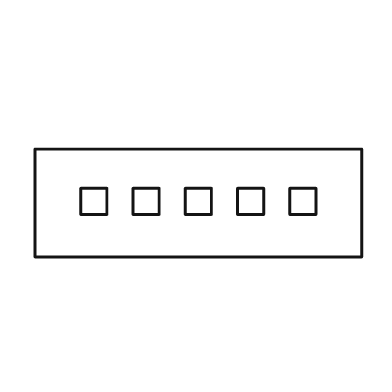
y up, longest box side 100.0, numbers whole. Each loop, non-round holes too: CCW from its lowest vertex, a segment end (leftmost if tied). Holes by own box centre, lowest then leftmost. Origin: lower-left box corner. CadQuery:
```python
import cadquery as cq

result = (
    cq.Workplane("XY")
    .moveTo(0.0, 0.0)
    .lineTo(100.0, 0.0)
    .lineTo(100.0, 33.0)
    .lineTo(0.0, 33.0)
    .close()
    .moveTo(14.0, 13.0)
    .lineTo(22.0, 13.0)
    .lineTo(22.0, 21.0)
    .lineTo(14.0, 21.0)
    .close()
    .moveTo(30.0, 13.0)
    .lineTo(38.0, 13.0)
    .lineTo(38.0, 21.0)
    .lineTo(30.0, 21.0)
    .close()
    .moveTo(46.0, 13.0)
    .lineTo(54.0, 13.0)
    .lineTo(54.0, 21.0)
    .lineTo(46.0, 21.0)
    .close()
    .moveTo(62.0, 13.0)
    .lineTo(70.0, 13.0)
    .lineTo(70.0, 21.0)
    .lineTo(62.0, 21.0)
    .close()
    .moveTo(78.0, 13.0)
    .lineTo(86.0, 13.0)
    .lineTo(86.0, 21.0)
    .lineTo(78.0, 21.0)
    .close()
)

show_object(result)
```